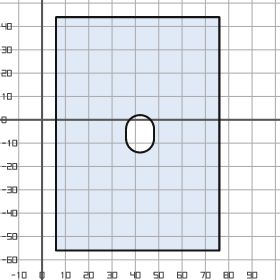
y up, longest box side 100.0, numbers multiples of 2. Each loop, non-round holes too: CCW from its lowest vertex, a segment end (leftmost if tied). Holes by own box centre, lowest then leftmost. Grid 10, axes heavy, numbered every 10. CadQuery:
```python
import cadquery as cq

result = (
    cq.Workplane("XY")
    .moveTo(6.0, -56.0)
    .lineTo(76.0, -56.0)
    .lineTo(76.0, 44.0)
    .lineTo(6.0, 44.0)
    .close()
    .moveTo(36.0, -8.0)
    .threePointArc((42.0, -14.0), (48.0, -8.0))
    .lineTo(48.0, -4.0)
    .threePointArc((42.0, 2.0), (36.0, -4.0))
    .close()
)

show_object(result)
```